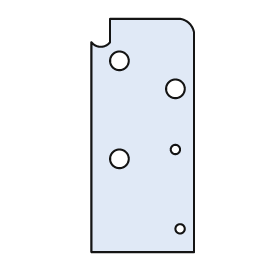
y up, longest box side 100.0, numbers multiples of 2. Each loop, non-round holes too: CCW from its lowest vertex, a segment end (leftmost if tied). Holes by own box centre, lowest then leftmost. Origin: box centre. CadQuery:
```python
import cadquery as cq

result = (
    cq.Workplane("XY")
    .moveTo(-22.0, -50.0)
    .lineTo(22.0, -50.0)
    .lineTo(22.0, 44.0)
    .threePointArc((20.0, 48.0), (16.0, 50.0))
    .lineTo(-14.0, 50.0)
    .lineTo(-14.0, 40.0)
    .threePointArc((-18.0, 38.0), (-22.0, 40.0))
    .close()
    .moveTo(16.0, -40.0)
    .circle(2.0)
    .moveTo(-10.0, -10.0)
    .circle(4.0)
    .moveTo(14.0, -6.0)
    .circle(2.0)
    .moveTo(14.0, 20.0)
    .circle(4.0)
    .moveTo(-10.0, 32.0)
    .circle(4.0)
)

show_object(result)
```